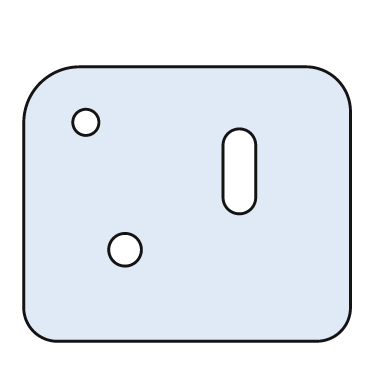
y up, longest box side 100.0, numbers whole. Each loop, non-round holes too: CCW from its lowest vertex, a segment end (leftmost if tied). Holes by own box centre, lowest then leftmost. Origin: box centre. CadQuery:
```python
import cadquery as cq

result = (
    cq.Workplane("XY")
    .moveTo(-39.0, -42.0)
    .lineTo(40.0, -42.0)
    .threePointArc((47.0, -39.0), (50.0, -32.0))
    .lineTo(50.0, 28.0)
    .threePointArc((46.0, 38.0), (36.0, 42.0))
    .lineTo(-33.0, 42.0)
    .threePointArc((-45.0, 37.0), (-50.0, 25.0))
    .lineTo(-50.0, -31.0)
    .threePointArc((-47.0, -39.0), (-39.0, -42.0))
    .close()
    .moveTo(-19.0, -14.0)
    .circle(5.0)
    .moveTo(11.0, 2.0)
    .threePointArc((16.0, -3.0), (21.0, 2.0))
    .lineTo(21.0, 18.0)
    .threePointArc((16.0, 23.0), (11.0, 18.0))
    .close()
    .moveTo(-31.0, 25.0)
    .circle(4.0)
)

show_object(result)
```